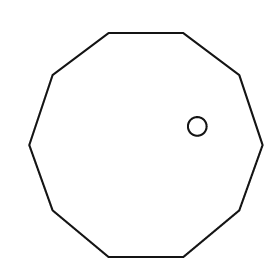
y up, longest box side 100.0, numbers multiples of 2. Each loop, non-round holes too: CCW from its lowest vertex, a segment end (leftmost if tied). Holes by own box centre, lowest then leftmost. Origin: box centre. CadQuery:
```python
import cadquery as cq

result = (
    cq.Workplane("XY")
    .moveTo(-16.0, -48.0)
    .lineTo(16.0, -48.0)
    .lineTo(40.0, -28.0)
    .lineTo(50.0, 0.0)
    .lineTo(40.0, 30.0)
    .lineTo(16.0, 48.0)
    .lineTo(-16.0, 48.0)
    .lineTo(-40.0, 30.0)
    .lineTo(-50.0, 0.0)
    .lineTo(-40.0, -28.0)
    .close()
    .moveTo(22.0, 8.0)
    .circle(4.0)
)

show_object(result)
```